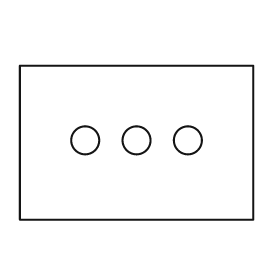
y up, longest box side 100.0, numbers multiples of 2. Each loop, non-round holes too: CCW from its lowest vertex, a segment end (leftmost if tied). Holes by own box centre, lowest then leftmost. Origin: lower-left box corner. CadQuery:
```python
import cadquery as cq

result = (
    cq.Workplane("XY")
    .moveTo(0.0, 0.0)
    .lineTo(100.0, 0.0)
    .lineTo(100.0, 66.0)
    .lineTo(0.0, 66.0)
    .close()
    .moveTo(28.0, 34.0)
    .circle(6.0)
    .moveTo(50.0, 34.0)
    .circle(6.0)
    .moveTo(72.0, 34.0)
    .circle(6.0)
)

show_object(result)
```